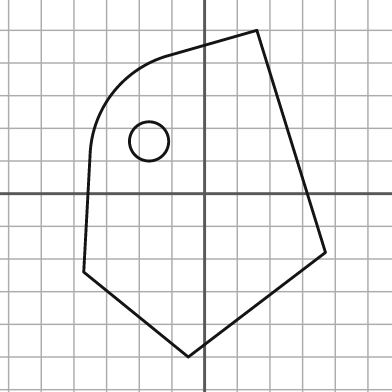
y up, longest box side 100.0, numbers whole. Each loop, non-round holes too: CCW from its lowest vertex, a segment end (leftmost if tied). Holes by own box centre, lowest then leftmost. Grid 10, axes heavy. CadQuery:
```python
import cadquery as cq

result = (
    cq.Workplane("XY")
    .moveTo(-5.0, -50.0)
    .lineTo(37.0, -18.0)
    .lineTo(16.0, 50.0)
    .lineTo(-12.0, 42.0)
    .threePointArc((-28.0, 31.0), (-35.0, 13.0))
    .lineTo(-37.0, -24.0)
    .close()
    .moveTo(-17.0, 16.0)
    .circle(6.0)
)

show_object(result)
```